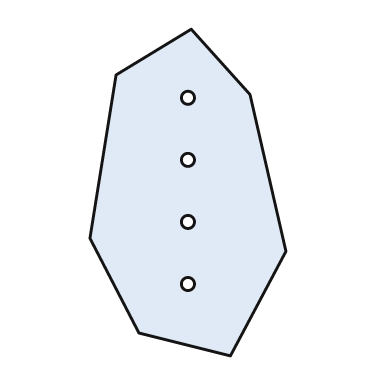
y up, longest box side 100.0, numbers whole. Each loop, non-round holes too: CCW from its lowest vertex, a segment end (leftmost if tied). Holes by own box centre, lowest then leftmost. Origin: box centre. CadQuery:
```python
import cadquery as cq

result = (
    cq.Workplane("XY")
    .moveTo(13.0, -50.0)
    .lineTo(30.0, -18.0)
    .lineTo(19.0, 30.0)
    .lineTo(1.0, 50.0)
    .lineTo(-22.0, 36.0)
    .lineTo(-30.0, -14.0)
    .lineTo(-15.0, -43.0)
    .close()
    .moveTo(0.0, -28.0)
    .circle(2.0)
    .moveTo(0.0, -9.0)
    .circle(2.0)
    .moveTo(0.0, 10.0)
    .circle(2.0)
    .moveTo(0.0, 29.0)
    .circle(2.0)
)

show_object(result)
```